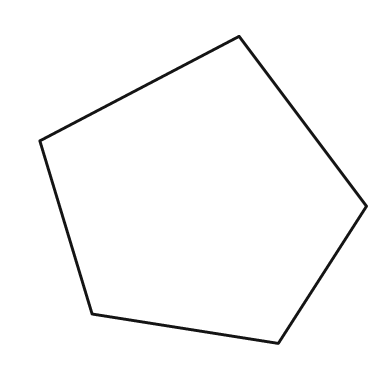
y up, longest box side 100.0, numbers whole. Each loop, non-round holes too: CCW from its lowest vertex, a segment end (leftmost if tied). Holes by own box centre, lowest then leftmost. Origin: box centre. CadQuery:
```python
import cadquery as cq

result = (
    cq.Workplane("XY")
    .moveTo(23.0, -47.0)
    .lineTo(50.0, -5.0)
    .lineTo(11.0, 47.0)
    .lineTo(-50.0, 15.0)
    .lineTo(-34.0, -38.0)
    .close()
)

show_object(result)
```